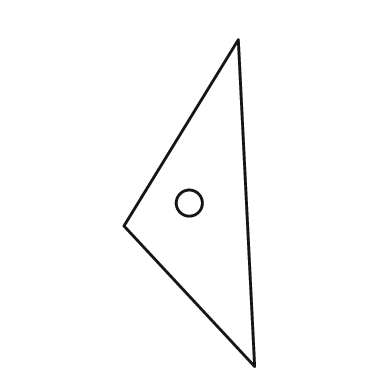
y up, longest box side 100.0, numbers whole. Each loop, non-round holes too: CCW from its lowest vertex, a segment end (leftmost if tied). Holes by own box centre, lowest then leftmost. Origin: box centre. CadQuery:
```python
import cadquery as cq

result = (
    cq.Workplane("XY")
    .moveTo(20.0, -50.0)
    .lineTo(15.0, 50.0)
    .lineTo(-20.0, -7.0)
    .close()
    .moveTo(0.0, 0.0)
    .circle(4.0)
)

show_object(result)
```